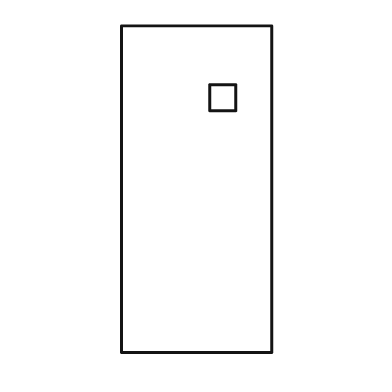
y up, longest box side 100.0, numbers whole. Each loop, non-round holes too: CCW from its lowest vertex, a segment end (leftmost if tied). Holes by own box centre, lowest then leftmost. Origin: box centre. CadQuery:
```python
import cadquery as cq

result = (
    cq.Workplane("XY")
    .moveTo(-23.0, -50.0)
    .lineTo(23.0, -50.0)
    .lineTo(23.0, 50.0)
    .lineTo(-23.0, 50.0)
    .close()
    .moveTo(4.0, 24.0)
    .lineTo(12.0, 24.0)
    .lineTo(12.0, 32.0)
    .lineTo(4.0, 32.0)
    .close()
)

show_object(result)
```